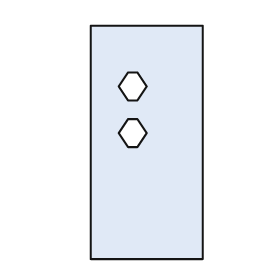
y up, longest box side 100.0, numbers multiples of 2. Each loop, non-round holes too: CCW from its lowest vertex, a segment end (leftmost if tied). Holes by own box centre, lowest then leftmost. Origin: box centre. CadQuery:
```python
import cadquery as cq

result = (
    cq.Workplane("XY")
    .moveTo(-24.0, -50.0)
    .lineTo(24.0, -50.0)
    .lineTo(24.0, 50.0)
    .lineTo(-24.0, 50.0)
    .close()
    .moveTo(-8.0, -2.0)
    .lineTo(-4.0, -2.0)
    .lineTo(0.0, 4.0)
    .lineTo(-4.0, 10.0)
    .lineTo(-8.0, 10.0)
    .lineTo(-12.0, 4.0)
    .close()
    .moveTo(-8.0, 18.0)
    .lineTo(-4.0, 18.0)
    .lineTo(0.0, 24.0)
    .lineTo(-4.0, 30.0)
    .lineTo(-8.0, 30.0)
    .lineTo(-12.0, 24.0)
    .close()
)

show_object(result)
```